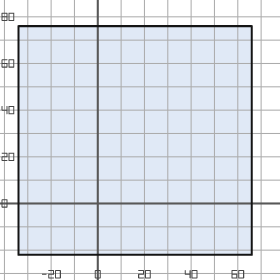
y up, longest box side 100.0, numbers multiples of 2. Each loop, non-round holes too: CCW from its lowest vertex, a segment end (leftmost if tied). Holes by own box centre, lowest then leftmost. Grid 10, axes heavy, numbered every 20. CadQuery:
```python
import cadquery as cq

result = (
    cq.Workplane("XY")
    .moveTo(-34.0, -22.0)
    .lineTo(66.0, -22.0)
    .lineTo(66.0, 76.0)
    .lineTo(-34.0, 76.0)
    .close()
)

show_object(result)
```